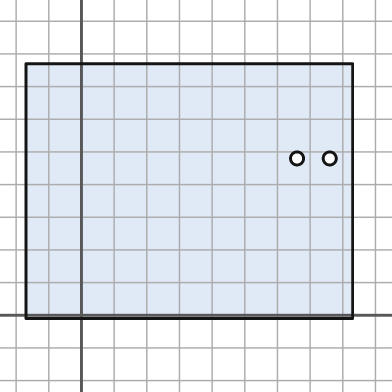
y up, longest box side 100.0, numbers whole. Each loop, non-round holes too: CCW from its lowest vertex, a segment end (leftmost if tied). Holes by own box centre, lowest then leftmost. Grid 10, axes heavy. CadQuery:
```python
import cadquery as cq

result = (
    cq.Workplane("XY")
    .moveTo(-17.0, -1.0)
    .lineTo(83.0, -1.0)
    .lineTo(83.0, 77.0)
    .lineTo(-17.0, 77.0)
    .close()
    .moveTo(66.0, 48.0)
    .circle(2.0)
    .moveTo(76.0, 48.0)
    .circle(2.0)
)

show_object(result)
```